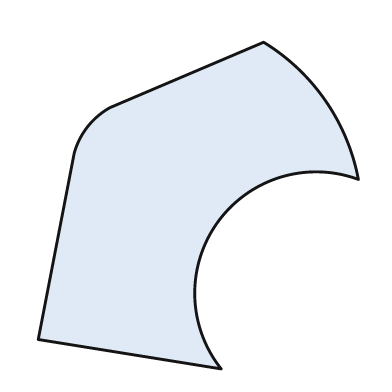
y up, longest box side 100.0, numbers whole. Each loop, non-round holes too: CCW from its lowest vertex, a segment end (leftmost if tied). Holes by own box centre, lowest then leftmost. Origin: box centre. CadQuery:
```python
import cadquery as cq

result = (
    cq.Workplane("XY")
    .moveTo(7.0, -50.0)
    .threePointArc((6.0, -5.0), (49.0, 8.0))
    .threePointArc((39.0, 32.0), (20.0, 50.0))
    .lineTo(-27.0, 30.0)
    .threePointArc((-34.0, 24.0), (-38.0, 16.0))
    .lineTo(-49.0, -41.0)
    .close()
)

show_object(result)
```